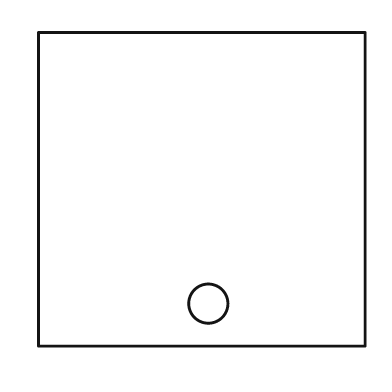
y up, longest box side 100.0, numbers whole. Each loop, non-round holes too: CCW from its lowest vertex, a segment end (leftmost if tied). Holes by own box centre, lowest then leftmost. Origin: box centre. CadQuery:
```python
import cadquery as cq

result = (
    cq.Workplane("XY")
    .moveTo(-50.0, -48.0)
    .lineTo(50.0, -48.0)
    .lineTo(50.0, 48.0)
    .lineTo(-50.0, 48.0)
    .close()
    .moveTo(2.0, -35.0)
    .circle(6.0)
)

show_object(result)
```